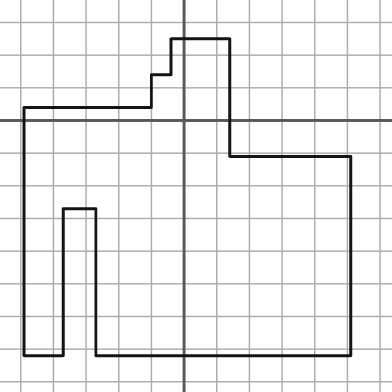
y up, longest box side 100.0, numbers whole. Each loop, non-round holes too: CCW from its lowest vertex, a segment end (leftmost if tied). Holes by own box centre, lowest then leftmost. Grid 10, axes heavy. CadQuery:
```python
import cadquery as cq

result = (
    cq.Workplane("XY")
    .moveTo(-49.0, -72.0)
    .lineTo(-37.0, -72.0)
    .lineTo(-37.0, -27.0)
    .lineTo(-27.0, -27.0)
    .lineTo(-27.0, -72.0)
    .lineTo(51.0, -72.0)
    .lineTo(51.0, -11.0)
    .lineTo(14.0, -11.0)
    .lineTo(14.0, 25.0)
    .lineTo(-4.0, 25.0)
    .lineTo(-4.0, 14.0)
    .lineTo(-10.0, 14.0)
    .lineTo(-10.0, 4.0)
    .lineTo(-49.0, 4.0)
    .close()
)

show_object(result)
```